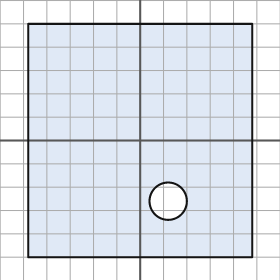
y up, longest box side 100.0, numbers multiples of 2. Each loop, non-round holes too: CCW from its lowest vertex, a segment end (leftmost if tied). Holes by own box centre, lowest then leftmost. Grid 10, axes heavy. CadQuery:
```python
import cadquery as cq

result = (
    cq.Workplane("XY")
    .moveTo(-48.0, -50.0)
    .lineTo(48.0, -50.0)
    .lineTo(48.0, 50.0)
    .lineTo(-48.0, 50.0)
    .close()
    .moveTo(12.0, -26.0)
    .circle(8.0)
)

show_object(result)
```